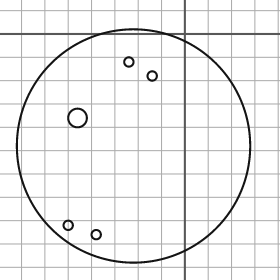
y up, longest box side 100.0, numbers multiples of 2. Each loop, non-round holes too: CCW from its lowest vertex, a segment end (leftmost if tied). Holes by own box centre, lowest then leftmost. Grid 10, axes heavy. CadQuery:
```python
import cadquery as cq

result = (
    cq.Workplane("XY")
    .moveTo(-22.0, -48.0)
    .circle(50.0)
    .moveTo(-38.0, -86.0)
    .circle(2.0)
    .moveTo(-50.0, -82.0)
    .circle(2.0)
    .moveTo(-46.0, -36.0)
    .circle(4.0)
    .moveTo(-14.0, -18.0)
    .circle(2.0)
    .moveTo(-24.0, -12.0)
    .circle(2.0)
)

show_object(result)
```